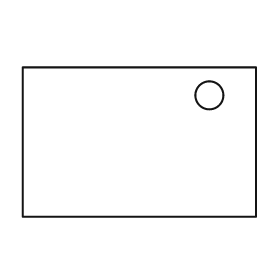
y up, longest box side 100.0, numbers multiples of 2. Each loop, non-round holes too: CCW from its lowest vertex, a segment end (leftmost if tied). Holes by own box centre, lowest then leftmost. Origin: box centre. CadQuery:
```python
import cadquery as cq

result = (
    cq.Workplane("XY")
    .moveTo(-50.0, -32.0)
    .lineTo(50.0, -32.0)
    .lineTo(50.0, 32.0)
    .lineTo(-50.0, 32.0)
    .close()
    .moveTo(30.0, 20.0)
    .circle(6.0)
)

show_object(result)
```